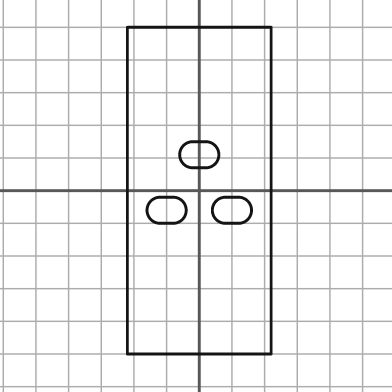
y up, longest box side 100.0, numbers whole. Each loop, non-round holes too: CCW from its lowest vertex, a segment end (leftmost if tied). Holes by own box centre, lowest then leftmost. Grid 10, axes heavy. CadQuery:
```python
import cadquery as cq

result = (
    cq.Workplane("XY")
    .moveTo(-22.0, -50.0)
    .lineTo(22.0, -50.0)
    .lineTo(22.0, 50.0)
    .lineTo(-22.0, 50.0)
    .close()
    .moveTo(-12.0, -10.0)
    .lineTo(-8.0, -10.0)
    .threePointArc((-4.0, -6.0), (-8.0, -2.0))
    .lineTo(-12.0, -2.0)
    .threePointArc((-16.0, -6.0), (-12.0, -10.0))
    .close()
    .moveTo(8.0, -10.0)
    .lineTo(12.0, -10.0)
    .threePointArc((16.0, -6.0), (12.0, -2.0))
    .lineTo(8.0, -2.0)
    .threePointArc((4.0, -6.0), (8.0, -10.0))
    .close()
    .moveTo(-2.0, 7.0)
    .lineTo(2.0, 7.0)
    .threePointArc((6.0, 11.0), (2.0, 15.0))
    .lineTo(-2.0, 15.0)
    .threePointArc((-6.0, 11.0), (-2.0, 7.0))
    .close()
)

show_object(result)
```